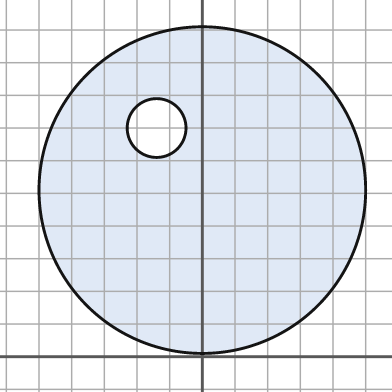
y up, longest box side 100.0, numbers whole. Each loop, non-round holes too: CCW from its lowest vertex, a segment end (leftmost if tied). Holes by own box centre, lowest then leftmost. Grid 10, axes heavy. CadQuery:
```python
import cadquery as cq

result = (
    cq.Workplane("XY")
    .moveTo(0.0, 51.0)
    .circle(50.0)
    .moveTo(-14.0, 70.0)
    .circle(9.0)
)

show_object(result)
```